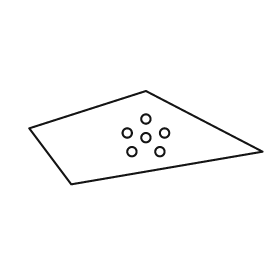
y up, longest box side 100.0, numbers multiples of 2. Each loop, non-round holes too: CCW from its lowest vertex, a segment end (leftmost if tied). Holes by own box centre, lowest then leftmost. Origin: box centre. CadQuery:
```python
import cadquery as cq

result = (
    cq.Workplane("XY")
    .moveTo(-32.0, -20.0)
    .lineTo(50.0, -6.0)
    .lineTo(0.0, 20.0)
    .lineTo(-50.0, 4.0)
    .close()
    .moveTo(-6.0, -6.0)
    .circle(2.0)
    .moveTo(6.0, -6.0)
    .circle(2.0)
    .moveTo(0.0, 0.0)
    .circle(2.0)
    .moveTo(-8.0, 2.0)
    .circle(2.0)
    .moveTo(8.0, 2.0)
    .circle(2.0)
    .moveTo(0.0, 8.0)
    .circle(2.0)
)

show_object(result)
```